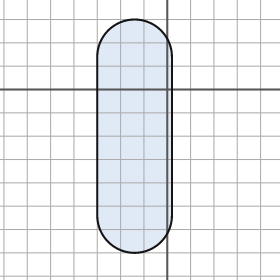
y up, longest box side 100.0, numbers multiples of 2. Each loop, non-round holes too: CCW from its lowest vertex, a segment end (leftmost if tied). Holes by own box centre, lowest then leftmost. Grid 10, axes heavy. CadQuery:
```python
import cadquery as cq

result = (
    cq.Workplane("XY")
    .moveTo(-30.0, -54.0)
    .threePointArc((-14.0, -70.0), (2.0, -54.0))
    .lineTo(2.0, 14.0)
    .threePointArc((-14.0, 30.0), (-30.0, 14.0))
    .close()
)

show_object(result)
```